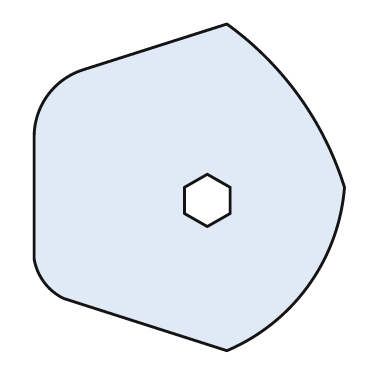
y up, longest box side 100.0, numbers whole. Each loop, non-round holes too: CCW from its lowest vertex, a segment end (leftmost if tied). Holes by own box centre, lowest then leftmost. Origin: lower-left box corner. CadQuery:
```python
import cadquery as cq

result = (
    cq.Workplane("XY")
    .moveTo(59.0, 0.0)
    .threePointArc((84.0, 20.0), (95.0, 50.0))
    .threePointArc((81.0, 78.0), (59.0, 100.0))
    .lineTo(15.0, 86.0)
    .threePointArc((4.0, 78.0), (0.0, 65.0))
    .lineTo(0.0, 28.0)
    .threePointArc((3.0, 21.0), (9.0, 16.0))
    .close()
    .moveTo(53.0, 38.0)
    .lineTo(60.0, 42.0)
    .lineTo(60.0, 50.0)
    .lineTo(53.0, 54.0)
    .lineTo(46.0, 50.0)
    .lineTo(46.0, 42.0)
    .close()
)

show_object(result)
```